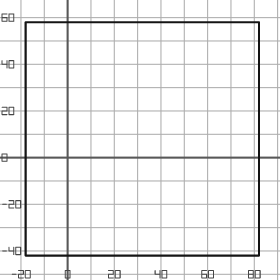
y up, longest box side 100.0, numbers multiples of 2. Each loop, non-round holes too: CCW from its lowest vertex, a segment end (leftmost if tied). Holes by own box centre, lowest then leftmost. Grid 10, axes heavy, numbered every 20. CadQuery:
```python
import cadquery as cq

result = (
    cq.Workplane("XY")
    .moveTo(-18.0, -42.0)
    .lineTo(82.0, -42.0)
    .lineTo(82.0, 58.0)
    .lineTo(-18.0, 58.0)
    .close()
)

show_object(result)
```